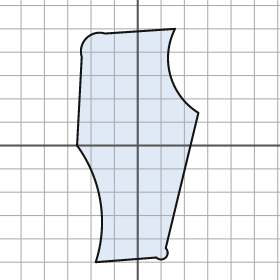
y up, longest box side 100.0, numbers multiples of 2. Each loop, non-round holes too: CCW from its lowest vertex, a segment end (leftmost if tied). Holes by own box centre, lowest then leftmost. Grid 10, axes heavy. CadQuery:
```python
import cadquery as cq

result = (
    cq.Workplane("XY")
    .moveTo(-18.0, -50.0)
    .lineTo(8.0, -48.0)
    .threePointArc((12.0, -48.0), (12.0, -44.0))
    .lineTo(26.0, 14.0)
    .threePointArc((14.0, 30.0), (16.0, 50.0))
    .lineTo(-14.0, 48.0)
    .threePointArc((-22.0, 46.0), (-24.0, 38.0))
    .lineTo(-26.0, 0.0)
    .threePointArc((-16.0, -24.0), (-18.0, -50.0))
    .close()
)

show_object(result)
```